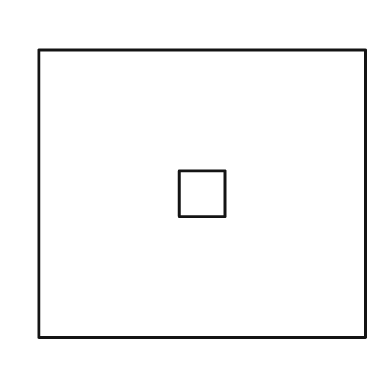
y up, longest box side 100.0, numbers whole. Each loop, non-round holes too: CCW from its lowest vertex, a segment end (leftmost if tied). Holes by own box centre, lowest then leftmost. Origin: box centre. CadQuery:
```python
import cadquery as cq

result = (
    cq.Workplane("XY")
    .moveTo(-50.0, -44.0)
    .lineTo(50.0, -44.0)
    .lineTo(50.0, 44.0)
    .lineTo(-50.0, 44.0)
    .close()
    .moveTo(-7.0, -7.0)
    .lineTo(7.0, -7.0)
    .lineTo(7.0, 7.0)
    .lineTo(-7.0, 7.0)
    .close()
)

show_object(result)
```